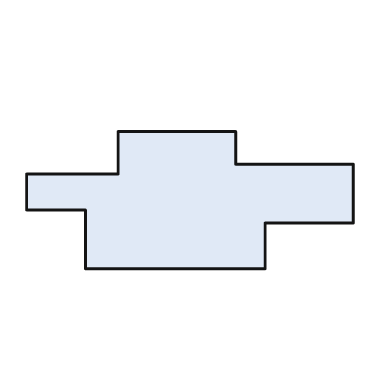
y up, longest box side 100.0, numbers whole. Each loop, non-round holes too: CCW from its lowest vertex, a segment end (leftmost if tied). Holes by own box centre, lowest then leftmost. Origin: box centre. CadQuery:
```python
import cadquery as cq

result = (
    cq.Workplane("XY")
    .moveTo(-32.0, -21.0)
    .lineTo(23.0, -21.0)
    .lineTo(23.0, -7.0)
    .lineTo(50.0, -7.0)
    .lineTo(50.0, 11.0)
    .lineTo(14.0, 11.0)
    .lineTo(14.0, 21.0)
    .lineTo(-22.0, 21.0)
    .lineTo(-22.0, 8.0)
    .lineTo(-50.0, 8.0)
    .lineTo(-50.0, -3.0)
    .lineTo(-32.0, -3.0)
    .close()
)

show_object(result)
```